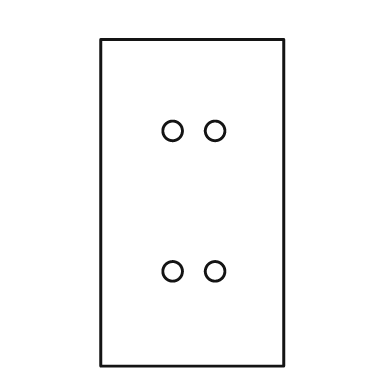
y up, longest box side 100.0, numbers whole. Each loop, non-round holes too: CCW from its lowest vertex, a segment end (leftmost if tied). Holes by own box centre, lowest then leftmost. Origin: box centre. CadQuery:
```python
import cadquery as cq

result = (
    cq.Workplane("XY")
    .moveTo(-28.0, -50.0)
    .lineTo(28.0, -50.0)
    .lineTo(28.0, 50.0)
    .lineTo(-28.0, 50.0)
    .close()
    .moveTo(-6.0, -21.0)
    .circle(3.0)
    .moveTo(7.0, -21.0)
    .circle(3.0)
    .moveTo(-6.0, 22.0)
    .circle(3.0)
    .moveTo(7.0, 22.0)
    .circle(3.0)
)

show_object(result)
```